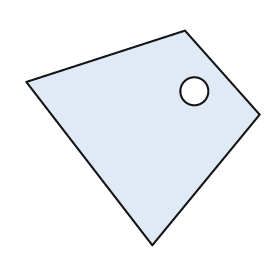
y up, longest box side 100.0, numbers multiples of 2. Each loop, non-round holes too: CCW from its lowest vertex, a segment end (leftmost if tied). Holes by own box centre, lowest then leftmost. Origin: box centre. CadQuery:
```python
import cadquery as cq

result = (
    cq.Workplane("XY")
    .moveTo(4.0, -46.0)
    .lineTo(50.0, 10.0)
    .lineTo(18.0, 46.0)
    .lineTo(-50.0, 24.0)
    .close()
    .moveTo(22.0, 20.0)
    .circle(6.0)
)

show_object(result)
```